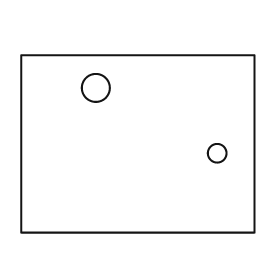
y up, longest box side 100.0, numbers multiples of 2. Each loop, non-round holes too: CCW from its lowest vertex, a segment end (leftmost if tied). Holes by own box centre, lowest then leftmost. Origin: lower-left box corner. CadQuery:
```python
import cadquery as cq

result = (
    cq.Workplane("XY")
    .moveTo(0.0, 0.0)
    .lineTo(100.0, 0.0)
    .lineTo(100.0, 76.0)
    .lineTo(0.0, 76.0)
    .close()
    .moveTo(84.0, 34.0)
    .circle(4.0)
    .moveTo(32.0, 62.0)
    .circle(6.0)
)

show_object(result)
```